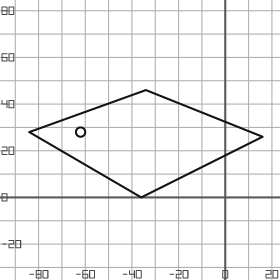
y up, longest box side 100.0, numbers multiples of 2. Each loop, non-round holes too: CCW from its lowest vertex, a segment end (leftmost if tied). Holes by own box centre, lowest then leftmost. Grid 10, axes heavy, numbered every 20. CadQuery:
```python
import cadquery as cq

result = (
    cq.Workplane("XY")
    .moveTo(-36.0, 0.0)
    .lineTo(16.0, 26.0)
    .lineTo(-34.0, 46.0)
    .lineTo(-84.0, 28.0)
    .close()
    .moveTo(-62.0, 28.0)
    .circle(2.0)
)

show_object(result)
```